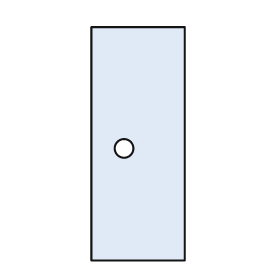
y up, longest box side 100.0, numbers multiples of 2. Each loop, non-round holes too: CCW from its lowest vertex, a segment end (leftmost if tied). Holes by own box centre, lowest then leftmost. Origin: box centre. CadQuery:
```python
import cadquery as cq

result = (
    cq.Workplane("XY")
    .moveTo(-20.0, -50.0)
    .lineTo(20.0, -50.0)
    .lineTo(20.0, 50.0)
    .lineTo(-20.0, 50.0)
    .close()
    .moveTo(-6.0, -2.0)
    .circle(4.0)
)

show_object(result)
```